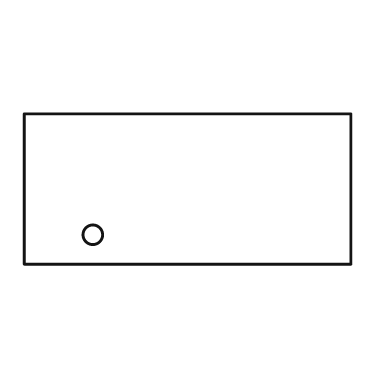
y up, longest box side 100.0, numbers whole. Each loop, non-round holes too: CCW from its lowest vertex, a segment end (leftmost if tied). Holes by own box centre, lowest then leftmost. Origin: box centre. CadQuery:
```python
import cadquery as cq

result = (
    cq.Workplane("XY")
    .moveTo(-50.0, -23.0)
    .lineTo(50.0, -23.0)
    .lineTo(50.0, 23.0)
    .lineTo(-50.0, 23.0)
    .close()
    .moveTo(-29.0, -14.0)
    .circle(3.0)
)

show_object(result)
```